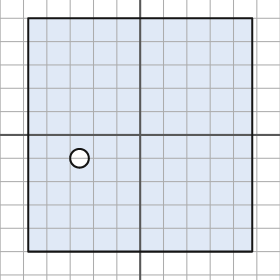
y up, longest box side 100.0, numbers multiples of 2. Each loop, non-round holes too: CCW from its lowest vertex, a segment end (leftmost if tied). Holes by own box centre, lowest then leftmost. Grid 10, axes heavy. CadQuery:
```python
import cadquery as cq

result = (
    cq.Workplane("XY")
    .moveTo(-48.0, -50.0)
    .lineTo(48.0, -50.0)
    .lineTo(48.0, 50.0)
    .lineTo(-48.0, 50.0)
    .close()
    .moveTo(-26.0, -10.0)
    .circle(4.0)
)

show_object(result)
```